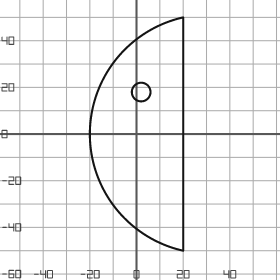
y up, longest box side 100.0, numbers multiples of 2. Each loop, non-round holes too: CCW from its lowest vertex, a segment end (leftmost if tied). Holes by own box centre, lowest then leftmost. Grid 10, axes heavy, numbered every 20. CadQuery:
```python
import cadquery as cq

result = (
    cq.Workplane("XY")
    .moveTo(20.0, -50.0)
    .lineTo(20.0, 50.0)
    .threePointArc((-20.0, 0.0), (20.0, -50.0))
    .close()
    .moveTo(2.0, 18.0)
    .circle(4.0)
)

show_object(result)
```